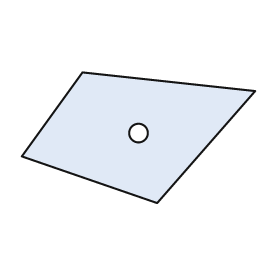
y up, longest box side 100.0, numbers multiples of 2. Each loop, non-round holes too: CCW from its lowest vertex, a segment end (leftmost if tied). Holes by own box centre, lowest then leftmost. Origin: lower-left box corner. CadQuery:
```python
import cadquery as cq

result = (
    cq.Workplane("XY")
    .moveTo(58.0, 0.0)
    .lineTo(100.0, 48.0)
    .lineTo(26.0, 56.0)
    .lineTo(0.0, 20.0)
    .close()
    .moveTo(50.0, 30.0)
    .circle(4.0)
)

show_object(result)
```